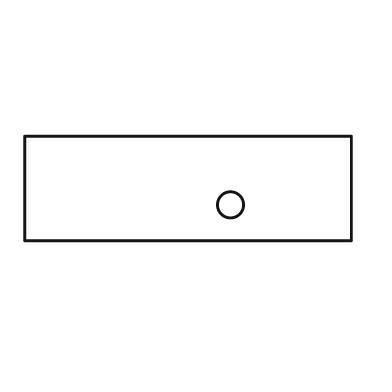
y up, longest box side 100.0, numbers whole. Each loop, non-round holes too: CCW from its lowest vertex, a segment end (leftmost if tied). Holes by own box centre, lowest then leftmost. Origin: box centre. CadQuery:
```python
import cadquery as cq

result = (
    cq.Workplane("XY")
    .moveTo(-50.0, -16.0)
    .lineTo(50.0, -16.0)
    .lineTo(50.0, 16.0)
    .lineTo(-50.0, 16.0)
    .close()
    .moveTo(13.0, -5.0)
    .circle(4.0)
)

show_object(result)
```